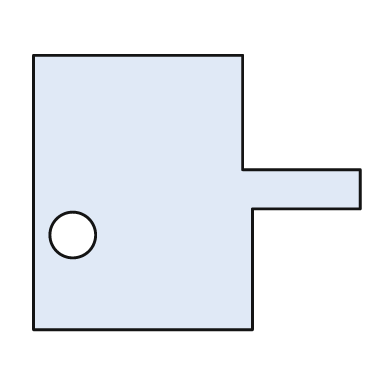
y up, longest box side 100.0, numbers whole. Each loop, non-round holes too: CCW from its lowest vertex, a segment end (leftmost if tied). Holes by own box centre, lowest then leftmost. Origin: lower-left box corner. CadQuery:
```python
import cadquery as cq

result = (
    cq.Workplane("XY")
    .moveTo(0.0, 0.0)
    .lineTo(67.0, 0.0)
    .lineTo(67.0, 37.0)
    .lineTo(100.0, 37.0)
    .lineTo(100.0, 49.0)
    .lineTo(64.0, 49.0)
    .lineTo(64.0, 84.0)
    .lineTo(0.0, 84.0)
    .close()
    .moveTo(12.0, 29.0)
    .circle(7.0)
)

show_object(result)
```